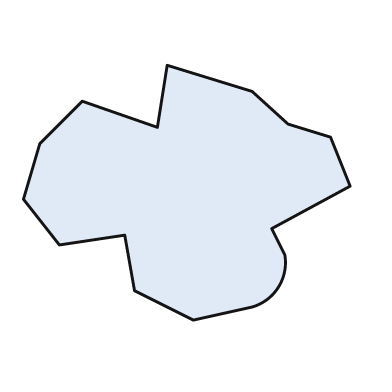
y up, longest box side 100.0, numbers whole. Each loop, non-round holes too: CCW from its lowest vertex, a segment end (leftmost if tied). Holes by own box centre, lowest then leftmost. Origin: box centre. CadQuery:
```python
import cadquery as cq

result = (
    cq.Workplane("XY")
    .moveTo(2.0, -39.0)
    .lineTo(20.0, -35.0)
    .threePointArc((28.0, -29.0), (30.0, -19.0))
    .lineTo(26.0, -11.0)
    .lineTo(50.0, 2.0)
    .lineTo(44.0, 17.0)
    .lineTo(31.0, 21.0)
    .lineTo(20.0, 31.0)
    .lineTo(-6.0, 39.0)
    .lineTo(-9.0, 20.0)
    .lineTo(-32.0, 28.0)
    .lineTo(-45.0, 15.0)
    .lineTo(-50.0, -2.0)
    .lineTo(-39.0, -16.0)
    .lineTo(-19.0, -13.0)
    .lineTo(-16.0, -30.0)
    .close()
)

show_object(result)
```